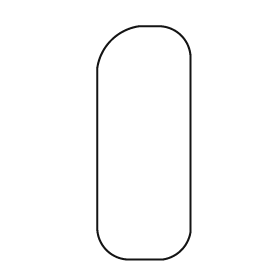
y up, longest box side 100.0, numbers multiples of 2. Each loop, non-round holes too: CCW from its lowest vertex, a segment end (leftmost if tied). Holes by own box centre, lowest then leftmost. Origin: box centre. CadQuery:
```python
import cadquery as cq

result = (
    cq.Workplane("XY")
    .moveTo(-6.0, -50.0)
    .lineTo(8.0, -50.0)
    .threePointArc((16.0, -46.0), (20.0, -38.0))
    .lineTo(20.0, 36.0)
    .threePointArc((16.0, 46.0), (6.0, 50.0))
    .lineTo(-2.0, 50.0)
    .threePointArc((-14.0, 44.0), (-20.0, 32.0))
    .lineTo(-20.0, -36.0)
    .threePointArc((-16.0, -46.0), (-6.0, -50.0))
    .close()
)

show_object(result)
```